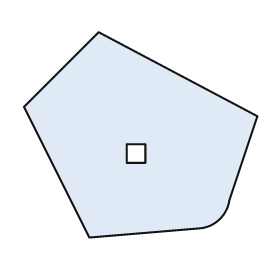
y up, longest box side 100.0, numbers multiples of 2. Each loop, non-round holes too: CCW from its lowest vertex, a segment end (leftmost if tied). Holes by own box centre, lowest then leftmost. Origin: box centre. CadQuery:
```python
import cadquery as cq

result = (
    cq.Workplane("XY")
    .moveTo(-22.0, -44.0)
    .lineTo(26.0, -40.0)
    .threePointArc((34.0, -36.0), (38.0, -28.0))
    .lineTo(50.0, 8.0)
    .lineTo(-18.0, 44.0)
    .lineTo(-50.0, 12.0)
    .close()
    .moveTo(-6.0, -12.0)
    .lineTo(2.0, -12.0)
    .lineTo(2.0, -4.0)
    .lineTo(-6.0, -4.0)
    .close()
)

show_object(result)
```